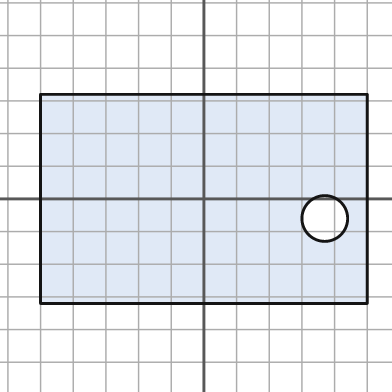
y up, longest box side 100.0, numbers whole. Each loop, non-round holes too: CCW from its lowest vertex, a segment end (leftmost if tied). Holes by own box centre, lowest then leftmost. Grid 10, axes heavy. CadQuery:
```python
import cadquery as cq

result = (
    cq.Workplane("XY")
    .moveTo(-50.0, -32.0)
    .lineTo(50.0, -32.0)
    .lineTo(50.0, 32.0)
    .lineTo(-50.0, 32.0)
    .close()
    .moveTo(37.0, -6.0)
    .circle(7.0)
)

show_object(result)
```